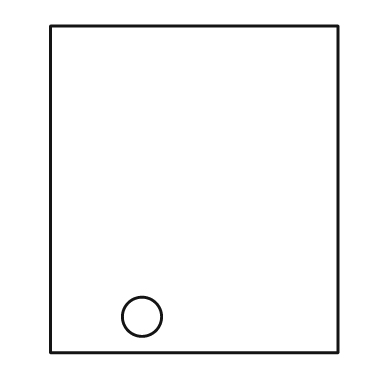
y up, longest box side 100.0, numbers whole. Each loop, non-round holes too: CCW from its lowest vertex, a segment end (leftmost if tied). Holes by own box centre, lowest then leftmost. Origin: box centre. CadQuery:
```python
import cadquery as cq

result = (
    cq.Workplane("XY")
    .moveTo(-44.0, -50.0)
    .lineTo(44.0, -50.0)
    .lineTo(44.0, 50.0)
    .lineTo(-44.0, 50.0)
    .close()
    .moveTo(-16.0, -39.0)
    .circle(6.0)
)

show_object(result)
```